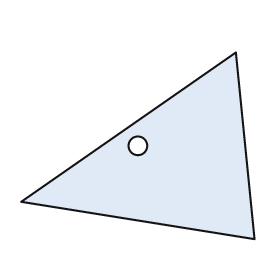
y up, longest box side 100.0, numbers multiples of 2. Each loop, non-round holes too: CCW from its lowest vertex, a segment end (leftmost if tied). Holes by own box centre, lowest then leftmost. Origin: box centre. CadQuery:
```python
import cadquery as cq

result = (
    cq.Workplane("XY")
    .moveTo(50.0, -40.0)
    .lineTo(42.0, 40.0)
    .lineTo(-50.0, -24.0)
    .close()
    .moveTo(0.0, 0.0)
    .circle(4.0)
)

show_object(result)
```